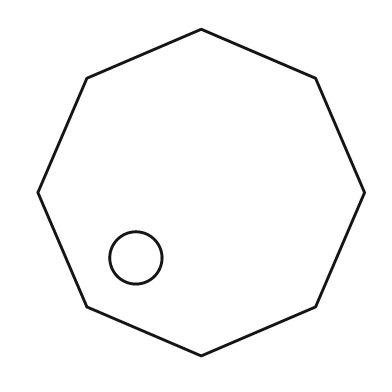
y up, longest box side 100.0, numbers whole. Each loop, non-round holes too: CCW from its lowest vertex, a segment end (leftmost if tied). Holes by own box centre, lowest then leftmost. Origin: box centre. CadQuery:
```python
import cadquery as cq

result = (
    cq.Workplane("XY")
    .moveTo(0.0, -50.0)
    .lineTo(35.0, -35.0)
    .lineTo(50.0, 0.0)
    .lineTo(35.0, 35.0)
    .lineTo(0.0, 50.0)
    .lineTo(-35.0, 35.0)
    .lineTo(-50.0, 0.0)
    .lineTo(-35.0, -35.0)
    .close()
    .moveTo(-20.0, -20.0)
    .circle(8.0)
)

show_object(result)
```